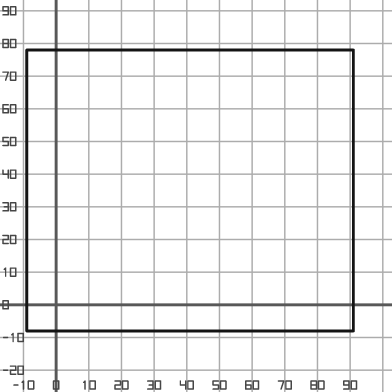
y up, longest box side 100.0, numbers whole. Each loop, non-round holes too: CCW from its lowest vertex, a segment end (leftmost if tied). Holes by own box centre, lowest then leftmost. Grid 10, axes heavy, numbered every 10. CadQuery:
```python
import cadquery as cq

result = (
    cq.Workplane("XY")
    .moveTo(-9.0, -8.0)
    .lineTo(91.0, -8.0)
    .lineTo(91.0, 78.0)
    .lineTo(-9.0, 78.0)
    .close()
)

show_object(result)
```